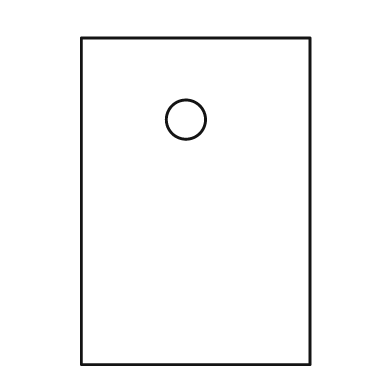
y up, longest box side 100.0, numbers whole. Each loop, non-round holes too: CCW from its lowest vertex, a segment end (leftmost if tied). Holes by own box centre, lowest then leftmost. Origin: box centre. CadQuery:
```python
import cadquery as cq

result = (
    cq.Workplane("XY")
    .moveTo(-35.0, -50.0)
    .lineTo(35.0, -50.0)
    .lineTo(35.0, 50.0)
    .lineTo(-35.0, 50.0)
    .close()
    .moveTo(-3.0, 25.0)
    .circle(6.0)
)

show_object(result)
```